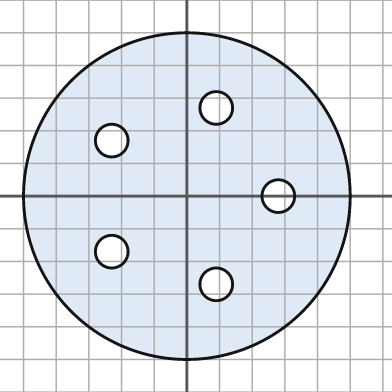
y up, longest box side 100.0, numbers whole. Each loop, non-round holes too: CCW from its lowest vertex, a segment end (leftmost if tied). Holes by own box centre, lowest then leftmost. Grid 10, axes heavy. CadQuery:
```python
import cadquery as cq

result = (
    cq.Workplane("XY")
    .moveTo(0.0, 0.0)
    .circle(50.0)
    .moveTo(9.0, -27.0)
    .circle(5.0)
    .moveTo(-23.0, -17.0)
    .circle(5.0)
    .moveTo(28.0, 0.0)
    .circle(5.0)
    .moveTo(-23.0, 17.0)
    .circle(5.0)
    .moveTo(9.0, 27.0)
    .circle(5.0)
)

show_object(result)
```